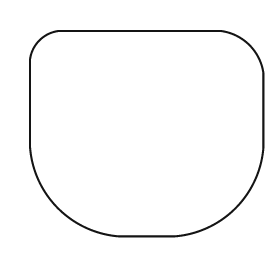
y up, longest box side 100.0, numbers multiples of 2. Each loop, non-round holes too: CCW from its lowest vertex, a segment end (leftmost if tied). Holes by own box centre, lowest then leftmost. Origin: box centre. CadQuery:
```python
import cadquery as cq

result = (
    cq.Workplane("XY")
    .moveTo(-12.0, -44.0)
    .lineTo(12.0, -44.0)
    .threePointArc((38.0, -32.0), (50.0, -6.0))
    .lineTo(50.0, 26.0)
    .threePointArc((44.0, 38.0), (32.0, 44.0))
    .lineTo(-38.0, 44.0)
    .threePointArc((-46.0, 40.0), (-50.0, 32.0))
    .lineTo(-50.0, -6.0)
    .threePointArc((-38.0, -32.0), (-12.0, -44.0))
    .close()
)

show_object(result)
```